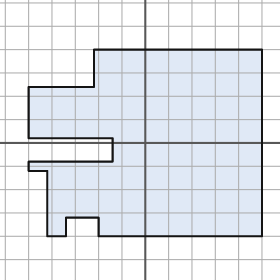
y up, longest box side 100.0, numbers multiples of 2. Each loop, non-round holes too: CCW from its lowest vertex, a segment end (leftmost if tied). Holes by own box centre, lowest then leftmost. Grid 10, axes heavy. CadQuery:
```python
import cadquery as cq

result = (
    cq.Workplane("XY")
    .moveTo(-42.0, -40.0)
    .lineTo(-34.0, -40.0)
    .lineTo(-34.0, -32.0)
    .lineTo(-20.0, -32.0)
    .lineTo(-20.0, -40.0)
    .lineTo(50.0, -40.0)
    .lineTo(50.0, 40.0)
    .lineTo(-22.0, 40.0)
    .lineTo(-22.0, 24.0)
    .lineTo(-50.0, 24.0)
    .lineTo(-50.0, 2.0)
    .lineTo(-14.0, 2.0)
    .lineTo(-14.0, -8.0)
    .lineTo(-50.0, -8.0)
    .lineTo(-50.0, -12.0)
    .lineTo(-42.0, -12.0)
    .close()
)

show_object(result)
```